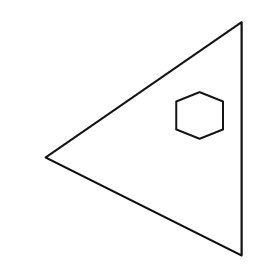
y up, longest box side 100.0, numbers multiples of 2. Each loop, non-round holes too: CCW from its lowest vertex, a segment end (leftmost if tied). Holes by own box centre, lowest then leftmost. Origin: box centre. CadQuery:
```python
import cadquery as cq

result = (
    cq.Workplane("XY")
    .moveTo(42.0, -50.0)
    .lineTo(42.0, 50.0)
    .lineTo(-42.0, -8.0)
    .close()
    .moveTo(24.0, 0.0)
    .lineTo(34.0, 4.0)
    .lineTo(34.0, 16.0)
    .lineTo(24.0, 20.0)
    .lineTo(14.0, 16.0)
    .lineTo(14.0, 4.0)
    .close()
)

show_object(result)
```